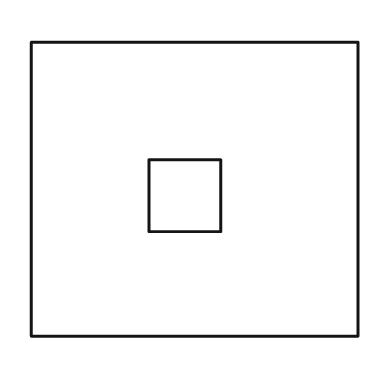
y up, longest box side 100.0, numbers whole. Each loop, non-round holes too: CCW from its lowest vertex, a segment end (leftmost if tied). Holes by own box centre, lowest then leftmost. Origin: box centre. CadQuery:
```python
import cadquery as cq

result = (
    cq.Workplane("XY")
    .moveTo(-50.0, -45.0)
    .lineTo(50.0, -45.0)
    .lineTo(50.0, 45.0)
    .lineTo(-50.0, 45.0)
    .close()
    .moveTo(-14.0, -13.0)
    .lineTo(8.0, -13.0)
    .lineTo(8.0, 9.0)
    .lineTo(-14.0, 9.0)
    .close()
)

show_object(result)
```